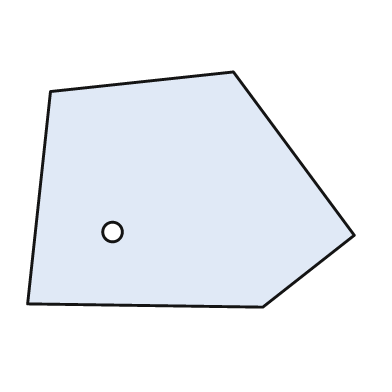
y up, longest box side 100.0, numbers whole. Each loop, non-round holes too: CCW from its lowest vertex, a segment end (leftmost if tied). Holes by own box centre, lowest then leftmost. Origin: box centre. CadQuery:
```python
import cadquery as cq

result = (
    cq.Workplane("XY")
    .moveTo(22.0, -36.0)
    .lineTo(50.0, -14.0)
    .lineTo(13.0, 36.0)
    .lineTo(-43.0, 30.0)
    .lineTo(-50.0, -35.0)
    .close()
    .moveTo(-24.0, -13.0)
    .circle(3.0)
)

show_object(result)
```